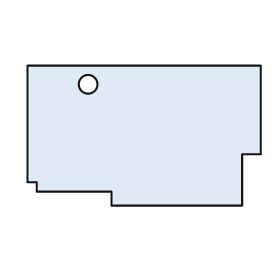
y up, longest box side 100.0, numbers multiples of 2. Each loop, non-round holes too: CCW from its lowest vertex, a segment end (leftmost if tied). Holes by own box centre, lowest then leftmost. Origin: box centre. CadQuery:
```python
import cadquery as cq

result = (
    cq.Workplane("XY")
    .moveTo(-14.0, -30.0)
    .lineTo(42.0, -30.0)
    .lineTo(42.0, -8.0)
    .lineTo(50.0, -8.0)
    .lineTo(50.0, 30.0)
    .lineTo(-50.0, 30.0)
    .lineTo(-50.0, -20.0)
    .lineTo(-46.0, -20.0)
    .lineTo(-46.0, -24.0)
    .lineTo(-14.0, -24.0)
    .close()
    .moveTo(-24.0, 22.0)
    .circle(4.0)
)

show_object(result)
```